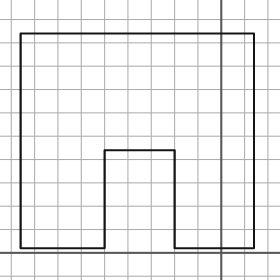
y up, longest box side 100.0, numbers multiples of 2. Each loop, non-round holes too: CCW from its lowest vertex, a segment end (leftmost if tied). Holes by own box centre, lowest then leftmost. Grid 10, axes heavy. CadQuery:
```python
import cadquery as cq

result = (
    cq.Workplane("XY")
    .moveTo(-86.0, 2.0)
    .lineTo(-50.0, 2.0)
    .lineTo(-50.0, 44.0)
    .lineTo(-20.0, 44.0)
    .lineTo(-20.0, 2.0)
    .lineTo(14.0, 2.0)
    .lineTo(14.0, 94.0)
    .lineTo(-86.0, 94.0)
    .close()
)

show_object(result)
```